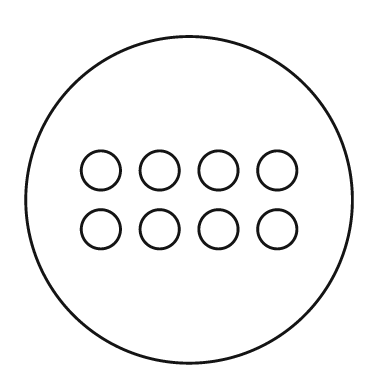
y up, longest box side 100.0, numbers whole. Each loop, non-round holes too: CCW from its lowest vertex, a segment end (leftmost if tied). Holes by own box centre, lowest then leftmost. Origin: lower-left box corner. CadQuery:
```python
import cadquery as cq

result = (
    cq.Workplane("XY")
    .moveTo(50.0, 50.0)
    .circle(50.0)
    .moveTo(23.0, 41.0)
    .circle(6.0)
    .moveTo(41.0, 41.0)
    .circle(6.0)
    .moveTo(59.0, 41.0)
    .circle(6.0)
    .moveTo(77.0, 41.0)
    .circle(6.0)
    .moveTo(23.0, 59.0)
    .circle(6.0)
    .moveTo(41.0, 59.0)
    .circle(6.0)
    .moveTo(59.0, 59.0)
    .circle(6.0)
    .moveTo(77.0, 59.0)
    .circle(6.0)
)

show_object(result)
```